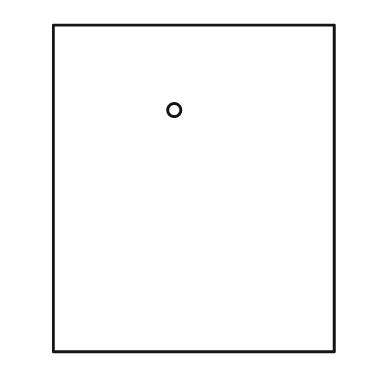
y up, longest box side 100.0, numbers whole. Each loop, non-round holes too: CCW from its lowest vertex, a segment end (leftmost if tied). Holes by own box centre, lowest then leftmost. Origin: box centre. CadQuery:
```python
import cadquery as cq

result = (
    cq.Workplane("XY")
    .moveTo(-43.0, -50.0)
    .lineTo(43.0, -50.0)
    .lineTo(43.0, 50.0)
    .lineTo(-43.0, 50.0)
    .close()
    .moveTo(-6.0, 24.0)
    .circle(2.0)
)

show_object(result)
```